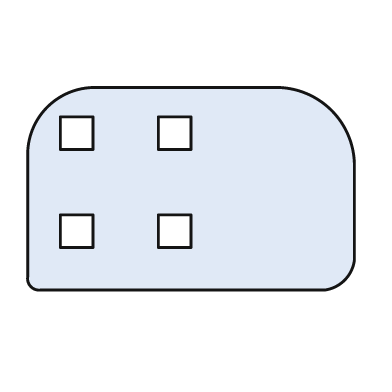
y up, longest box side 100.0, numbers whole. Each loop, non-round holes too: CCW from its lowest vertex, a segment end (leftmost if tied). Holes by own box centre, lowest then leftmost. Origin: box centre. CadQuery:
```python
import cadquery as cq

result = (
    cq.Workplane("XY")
    .moveTo(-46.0, -31.0)
    .lineTo(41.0, -31.0)
    .threePointArc((47.0, -28.0), (50.0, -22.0))
    .lineTo(50.0, 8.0)
    .threePointArc((43.0, 24.0), (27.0, 31.0))
    .lineTo(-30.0, 31.0)
    .threePointArc((-44.0, 25.0), (-50.0, 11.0))
    .lineTo(-50.0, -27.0)
    .threePointArc((-49.0, -30.0), (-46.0, -31.0))
    .close()
    .moveTo(-40.0, -18.0)
    .lineTo(-30.0, -18.0)
    .lineTo(-30.0, -8.0)
    .lineTo(-40.0, -8.0)
    .close()
    .moveTo(-10.0, -18.0)
    .lineTo(0.0, -18.0)
    .lineTo(0.0, -8.0)
    .lineTo(-10.0, -8.0)
    .close()
    .moveTo(-40.0, 12.0)
    .lineTo(-30.0, 12.0)
    .lineTo(-30.0, 22.0)
    .lineTo(-40.0, 22.0)
    .close()
    .moveTo(-10.0, 12.0)
    .lineTo(0.0, 12.0)
    .lineTo(0.0, 22.0)
    .lineTo(-10.0, 22.0)
    .close()
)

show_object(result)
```